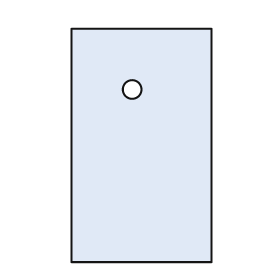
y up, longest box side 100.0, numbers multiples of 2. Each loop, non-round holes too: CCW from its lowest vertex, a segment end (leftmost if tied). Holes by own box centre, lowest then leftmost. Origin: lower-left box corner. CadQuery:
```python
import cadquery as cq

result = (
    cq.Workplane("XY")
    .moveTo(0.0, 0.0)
    .lineTo(60.0, 0.0)
    .lineTo(60.0, 100.0)
    .lineTo(0.0, 100.0)
    .close()
    .moveTo(26.0, 74.0)
    .circle(4.0)
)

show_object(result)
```